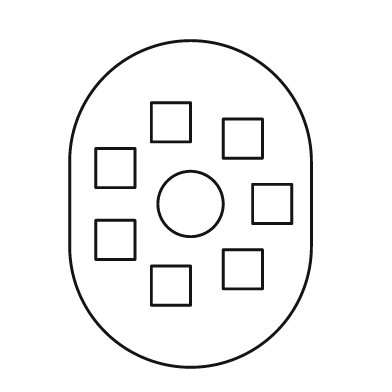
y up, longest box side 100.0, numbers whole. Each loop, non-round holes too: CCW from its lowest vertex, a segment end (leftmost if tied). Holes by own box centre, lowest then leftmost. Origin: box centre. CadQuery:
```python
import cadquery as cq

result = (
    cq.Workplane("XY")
    .moveTo(-37.0, -13.0)
    .threePointArc((0.0, -50.0), (37.0, -13.0))
    .lineTo(37.0, 13.0)
    .threePointArc((0.0, 50.0), (-37.0, 13.0))
    .close()
    .moveTo(-12.0, -31.0)
    .lineTo(0.0, -31.0)
    .lineTo(0.0, -19.0)
    .lineTo(-12.0, -19.0)
    .close()
    .moveTo(10.0, -26.0)
    .lineTo(22.0, -26.0)
    .lineTo(22.0, -14.0)
    .lineTo(10.0, -14.0)
    .close()
    .moveTo(-29.0, -17.0)
    .lineTo(-17.0, -17.0)
    .lineTo(-17.0, -5.0)
    .lineTo(-29.0, -5.0)
    .close()
    .moveTo(0.0, 0.0)
    .circle(10.0)
    .moveTo(19.0, -6.0)
    .lineTo(31.0, -6.0)
    .lineTo(31.0, 6.0)
    .lineTo(19.0, 6.0)
    .close()
    .moveTo(-29.0, 5.0)
    .lineTo(-17.0, 5.0)
    .lineTo(-17.0, 17.0)
    .lineTo(-29.0, 17.0)
    .close()
    .moveTo(10.0, 14.0)
    .lineTo(22.0, 14.0)
    .lineTo(22.0, 26.0)
    .lineTo(10.0, 26.0)
    .close()
    .moveTo(-12.0, 19.0)
    .lineTo(0.0, 19.0)
    .lineTo(0.0, 31.0)
    .lineTo(-12.0, 31.0)
    .close()
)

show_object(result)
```